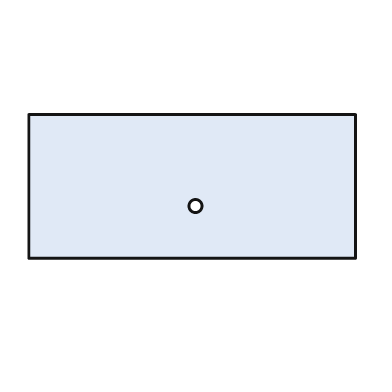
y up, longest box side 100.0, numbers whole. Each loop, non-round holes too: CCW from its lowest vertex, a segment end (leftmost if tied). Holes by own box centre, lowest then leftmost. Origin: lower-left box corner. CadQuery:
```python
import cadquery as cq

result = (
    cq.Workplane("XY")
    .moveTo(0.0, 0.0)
    .lineTo(100.0, 0.0)
    .lineTo(100.0, 44.0)
    .lineTo(0.0, 44.0)
    .close()
    .moveTo(51.0, 16.0)
    .circle(2.0)
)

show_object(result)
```